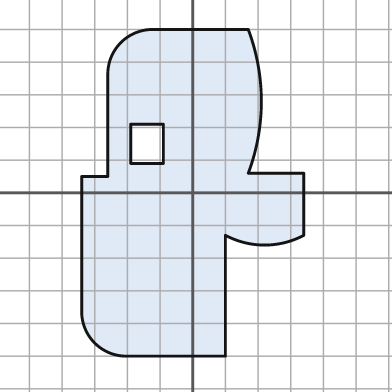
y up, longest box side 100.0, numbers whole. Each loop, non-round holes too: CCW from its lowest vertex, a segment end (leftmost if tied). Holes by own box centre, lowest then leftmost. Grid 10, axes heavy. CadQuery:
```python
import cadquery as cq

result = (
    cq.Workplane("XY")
    .moveTo(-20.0, -50.0)
    .lineTo(10.0, -50.0)
    .lineTo(10.0, -13.0)
    .threePointArc((22.0, -16.0), (34.0, -13.0))
    .lineTo(34.0, 6.0)
    .lineTo(17.0, 6.0)
    .threePointArc((21.0, 28.0), (17.0, 50.0))
    .lineTo(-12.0, 50.0)
    .threePointArc((-22.0, 46.0), (-26.0, 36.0))
    .lineTo(-26.0, 5.0)
    .lineTo(-34.0, 5.0)
    .lineTo(-34.0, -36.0)
    .threePointArc((-30.0, -46.0), (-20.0, -50.0))
    .close()
    .moveTo(-19.0, 9.0)
    .lineTo(-9.0, 9.0)
    .lineTo(-9.0, 21.0)
    .lineTo(-19.0, 21.0)
    .close()
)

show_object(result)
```